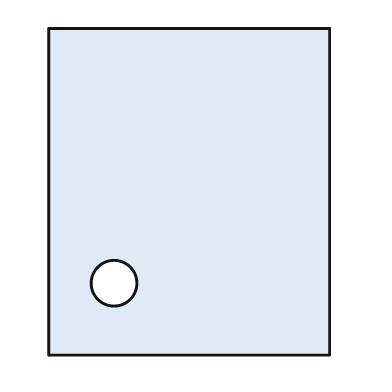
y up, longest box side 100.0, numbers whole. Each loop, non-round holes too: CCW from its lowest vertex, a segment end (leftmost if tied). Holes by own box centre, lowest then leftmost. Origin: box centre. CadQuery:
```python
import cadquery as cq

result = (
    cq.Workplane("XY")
    .moveTo(-43.0, -50.0)
    .lineTo(43.0, -50.0)
    .lineTo(43.0, 50.0)
    .lineTo(-43.0, 50.0)
    .close()
    .moveTo(-23.0, -28.0)
    .circle(7.0)
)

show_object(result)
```